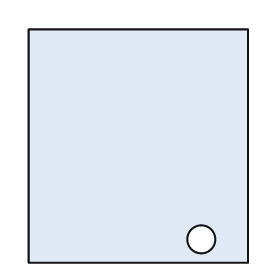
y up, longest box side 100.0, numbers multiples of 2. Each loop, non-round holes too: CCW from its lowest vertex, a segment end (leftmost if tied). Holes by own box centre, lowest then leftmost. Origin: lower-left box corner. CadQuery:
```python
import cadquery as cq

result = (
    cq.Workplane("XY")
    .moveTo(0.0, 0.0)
    .lineTo(94.0, 0.0)
    .lineTo(94.0, 100.0)
    .lineTo(0.0, 100.0)
    .close()
    .moveTo(74.0, 10.0)
    .circle(6.0)
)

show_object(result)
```